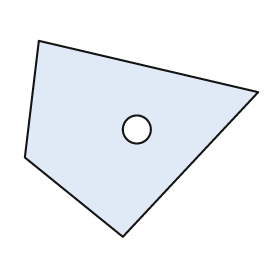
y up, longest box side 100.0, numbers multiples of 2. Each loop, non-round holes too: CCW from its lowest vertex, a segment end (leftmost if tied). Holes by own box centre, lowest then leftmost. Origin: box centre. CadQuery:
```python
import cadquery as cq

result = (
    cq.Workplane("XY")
    .moveTo(-8.0, -42.0)
    .lineTo(50.0, 20.0)
    .lineTo(-44.0, 42.0)
    .lineTo(-50.0, -8.0)
    .close()
    .moveTo(-2.0, 4.0)
    .circle(6.0)
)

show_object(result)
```